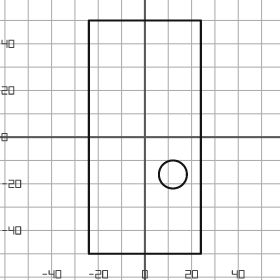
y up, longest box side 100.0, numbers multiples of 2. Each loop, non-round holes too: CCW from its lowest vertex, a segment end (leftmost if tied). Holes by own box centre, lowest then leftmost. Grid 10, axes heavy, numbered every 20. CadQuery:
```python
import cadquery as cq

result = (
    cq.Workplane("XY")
    .moveTo(-24.0, -50.0)
    .lineTo(24.0, -50.0)
    .lineTo(24.0, 50.0)
    .lineTo(-24.0, 50.0)
    .close()
    .moveTo(12.0, -16.0)
    .circle(6.0)
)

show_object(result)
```